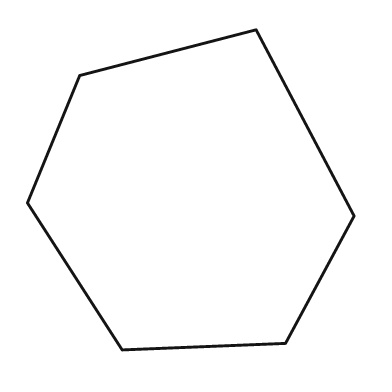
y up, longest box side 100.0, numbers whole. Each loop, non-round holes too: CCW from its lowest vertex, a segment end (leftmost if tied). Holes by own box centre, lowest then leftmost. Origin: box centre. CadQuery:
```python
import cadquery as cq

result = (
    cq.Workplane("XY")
    .moveTo(-21.0, -49.0)
    .lineTo(29.0, -47.0)
    .lineTo(50.0, -8.0)
    .lineTo(20.0, 49.0)
    .lineTo(-34.0, 35.0)
    .lineTo(-50.0, -4.0)
    .close()
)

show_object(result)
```